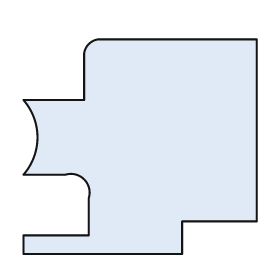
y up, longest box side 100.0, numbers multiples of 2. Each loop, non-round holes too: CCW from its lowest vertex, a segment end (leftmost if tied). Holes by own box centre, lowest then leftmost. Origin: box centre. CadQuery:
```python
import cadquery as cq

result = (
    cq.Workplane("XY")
    .moveTo(-50.0, -46.0)
    .lineTo(18.0, -46.0)
    .lineTo(18.0, -32.0)
    .lineTo(50.0, -32.0)
    .lineTo(50.0, 46.0)
    .lineTo(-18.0, 46.0)
    .threePointArc((-22.0, 44.0), (-24.0, 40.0))
    .lineTo(-24.0, 20.0)
    .lineTo(-50.0, 20.0)
    .threePointArc((-44.0, 4.0), (-50.0, -12.0))
    .lineTo(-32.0, -12.0)
    .threePointArc((-24.0, -14.0), (-22.0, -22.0))
    .lineTo(-22.0, -38.0)
    .lineTo(-50.0, -38.0)
    .close()
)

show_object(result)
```